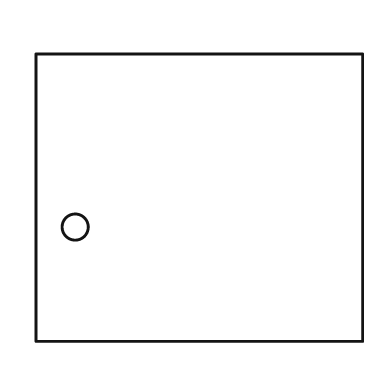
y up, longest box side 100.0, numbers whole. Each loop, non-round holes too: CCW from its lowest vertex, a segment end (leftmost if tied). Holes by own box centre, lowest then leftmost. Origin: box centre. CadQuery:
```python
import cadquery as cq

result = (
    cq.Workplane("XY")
    .moveTo(-50.0, -44.0)
    .lineTo(50.0, -44.0)
    .lineTo(50.0, 44.0)
    .lineTo(-50.0, 44.0)
    .close()
    .moveTo(-38.0, -9.0)
    .circle(4.0)
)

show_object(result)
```